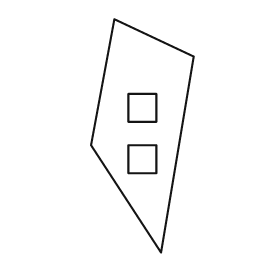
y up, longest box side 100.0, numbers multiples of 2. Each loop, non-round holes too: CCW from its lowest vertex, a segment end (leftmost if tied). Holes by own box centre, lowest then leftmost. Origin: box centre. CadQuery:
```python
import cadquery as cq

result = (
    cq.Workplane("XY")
    .moveTo(8.0, -50.0)
    .lineTo(22.0, 34.0)
    .lineTo(-12.0, 50.0)
    .lineTo(-22.0, -4.0)
    .close()
    .moveTo(-6.0, -16.0)
    .lineTo(6.0, -16.0)
    .lineTo(6.0, -4.0)
    .lineTo(-6.0, -4.0)
    .close()
    .moveTo(-6.0, 6.0)
    .lineTo(6.0, 6.0)
    .lineTo(6.0, 18.0)
    .lineTo(-6.0, 18.0)
    .close()
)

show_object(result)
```